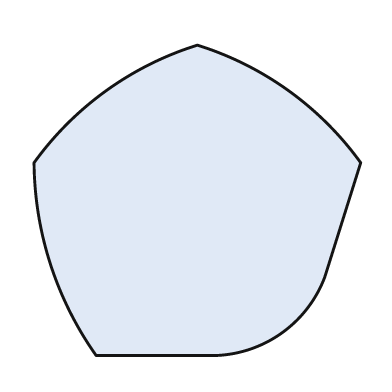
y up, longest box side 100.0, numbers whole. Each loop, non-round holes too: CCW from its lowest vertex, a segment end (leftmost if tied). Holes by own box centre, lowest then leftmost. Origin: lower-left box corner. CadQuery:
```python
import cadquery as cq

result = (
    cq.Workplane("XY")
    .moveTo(19.0, 0.0)
    .lineTo(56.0, 0.0)
    .threePointArc((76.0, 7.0), (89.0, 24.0))
    .lineTo(100.0, 59.0)
    .threePointArc((78.0, 81.0), (50.0, 95.0))
    .threePointArc((22.0, 81.0), (0.0, 59.0))
    .threePointArc((5.0, 28.0), (19.0, 0.0))
    .close()
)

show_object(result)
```